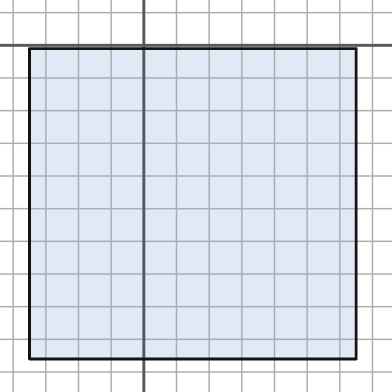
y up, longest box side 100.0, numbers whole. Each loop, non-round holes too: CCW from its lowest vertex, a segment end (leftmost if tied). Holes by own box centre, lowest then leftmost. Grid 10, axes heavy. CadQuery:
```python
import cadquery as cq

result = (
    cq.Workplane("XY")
    .moveTo(-35.0, -96.0)
    .lineTo(65.0, -96.0)
    .lineTo(65.0, -1.0)
    .lineTo(-35.0, -1.0)
    .close()
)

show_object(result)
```